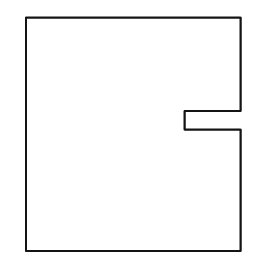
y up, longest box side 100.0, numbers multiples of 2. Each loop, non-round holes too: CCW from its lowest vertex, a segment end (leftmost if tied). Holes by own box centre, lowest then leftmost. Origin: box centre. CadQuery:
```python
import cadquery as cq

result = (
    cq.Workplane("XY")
    .moveTo(-46.0, -50.0)
    .lineTo(46.0, -50.0)
    .lineTo(46.0, 2.0)
    .lineTo(22.0, 2.0)
    .lineTo(22.0, 10.0)
    .lineTo(46.0, 10.0)
    .lineTo(46.0, 50.0)
    .lineTo(-46.0, 50.0)
    .close()
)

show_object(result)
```